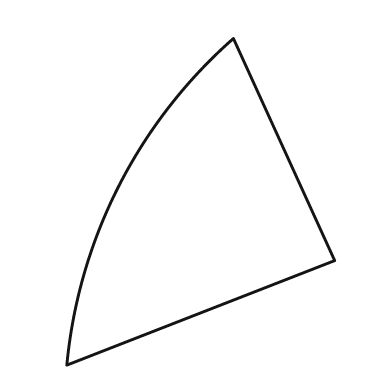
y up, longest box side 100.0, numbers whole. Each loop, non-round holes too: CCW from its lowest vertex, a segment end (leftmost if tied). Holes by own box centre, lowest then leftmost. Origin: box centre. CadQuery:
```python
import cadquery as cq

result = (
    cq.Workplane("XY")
    .moveTo(-41.0, -50.0)
    .lineTo(41.0, -18.0)
    .lineTo(10.0, 50.0)
    .threePointArc((-25.0, 5.0), (-41.0, -50.0))
    .close()
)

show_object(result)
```